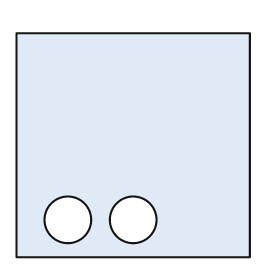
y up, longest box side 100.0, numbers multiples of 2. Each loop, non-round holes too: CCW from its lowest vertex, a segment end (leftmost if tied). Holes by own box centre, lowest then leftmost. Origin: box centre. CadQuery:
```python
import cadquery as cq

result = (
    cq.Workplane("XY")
    .moveTo(-50.0, -48.0)
    .lineTo(50.0, -48.0)
    .lineTo(50.0, 48.0)
    .lineTo(-50.0, 48.0)
    .close()
    .moveTo(-28.0, -32.0)
    .circle(10.0)
    .moveTo(0.0, -32.0)
    .circle(10.0)
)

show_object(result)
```